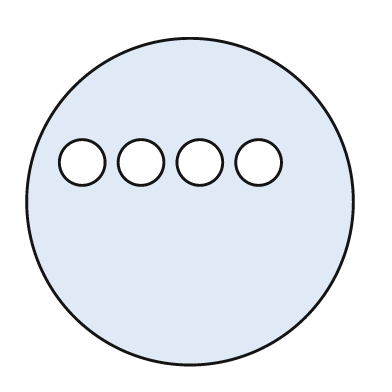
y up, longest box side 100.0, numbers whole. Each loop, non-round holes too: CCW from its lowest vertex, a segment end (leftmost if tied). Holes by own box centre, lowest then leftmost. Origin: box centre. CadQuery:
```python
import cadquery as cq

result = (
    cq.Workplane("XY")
    .moveTo(0.0, 0.0)
    .circle(50.0)
    .moveTo(-33.0, 12.0)
    .circle(7.0)
    .moveTo(-15.0, 12.0)
    .circle(7.0)
    .moveTo(3.0, 12.0)
    .circle(7.0)
    .moveTo(21.0, 12.0)
    .circle(7.0)
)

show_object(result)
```